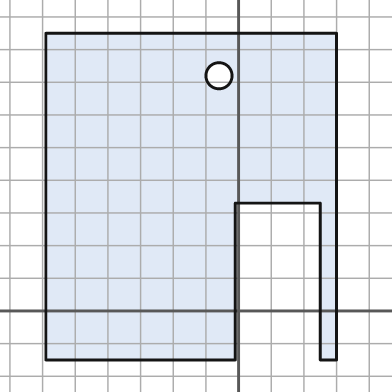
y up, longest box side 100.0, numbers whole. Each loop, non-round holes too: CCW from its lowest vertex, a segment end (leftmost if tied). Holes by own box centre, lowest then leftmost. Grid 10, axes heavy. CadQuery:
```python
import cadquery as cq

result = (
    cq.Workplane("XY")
    .moveTo(-59.0, -15.0)
    .lineTo(-1.0, -15.0)
    .lineTo(-1.0, 33.0)
    .lineTo(25.0, 33.0)
    .lineTo(25.0, -15.0)
    .lineTo(30.0, -15.0)
    .lineTo(30.0, 85.0)
    .lineTo(-59.0, 85.0)
    .close()
    .moveTo(-6.0, 72.0)
    .circle(4.0)
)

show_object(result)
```